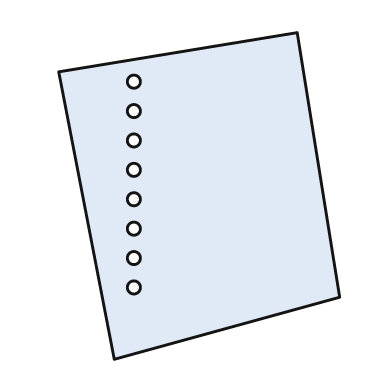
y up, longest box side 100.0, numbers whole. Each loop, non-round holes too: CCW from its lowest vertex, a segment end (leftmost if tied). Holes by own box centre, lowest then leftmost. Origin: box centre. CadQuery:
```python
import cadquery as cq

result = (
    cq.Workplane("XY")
    .moveTo(-26.0, -50.0)
    .lineTo(43.0, -31.0)
    .lineTo(30.0, 50.0)
    .lineTo(-43.0, 38.0)
    .close()
    .moveTo(-20.0, -28.0)
    .circle(2.0)
    .moveTo(-20.0, -19.0)
    .circle(2.0)
    .moveTo(-20.0, -10.0)
    .circle(2.0)
    .moveTo(-20.0, -1.0)
    .circle(2.0)
    .moveTo(-20.0, 8.0)
    .circle(2.0)
    .moveTo(-20.0, 17.0)
    .circle(2.0)
    .moveTo(-20.0, 26.0)
    .circle(2.0)
    .moveTo(-20.0, 35.0)
    .circle(2.0)
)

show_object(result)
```